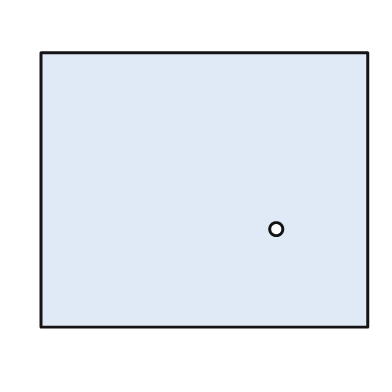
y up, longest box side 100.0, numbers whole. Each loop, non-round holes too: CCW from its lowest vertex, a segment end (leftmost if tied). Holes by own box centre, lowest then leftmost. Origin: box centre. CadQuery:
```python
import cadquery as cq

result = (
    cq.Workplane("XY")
    .moveTo(-50.0, -42.0)
    .lineTo(50.0, -42.0)
    .lineTo(50.0, 42.0)
    .lineTo(-50.0, 42.0)
    .close()
    .moveTo(22.0, -12.0)
    .circle(2.0)
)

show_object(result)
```